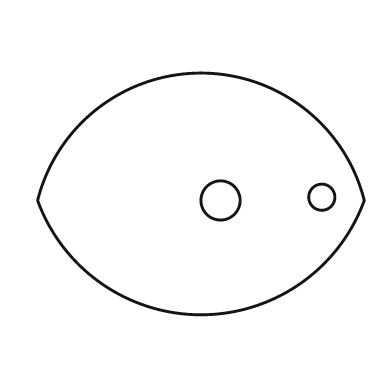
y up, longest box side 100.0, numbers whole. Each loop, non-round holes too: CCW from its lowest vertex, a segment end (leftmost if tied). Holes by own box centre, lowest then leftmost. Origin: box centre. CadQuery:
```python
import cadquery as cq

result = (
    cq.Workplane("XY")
    .moveTo(-50.0, -2.0)
    .threePointArc((0.0, -37.0), (50.0, -2.0))
    .threePointArc((0.0, 37.0), (-50.0, -2.0))
    .close()
    .moveTo(6.0, -2.0)
    .circle(6.0)
    .moveTo(37.0, -1.0)
    .circle(4.0)
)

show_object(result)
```